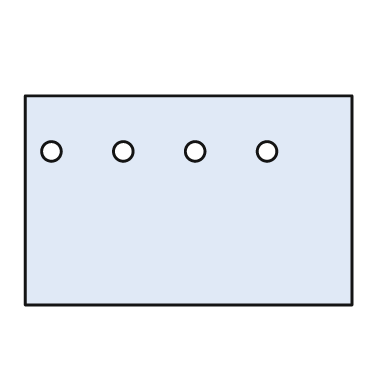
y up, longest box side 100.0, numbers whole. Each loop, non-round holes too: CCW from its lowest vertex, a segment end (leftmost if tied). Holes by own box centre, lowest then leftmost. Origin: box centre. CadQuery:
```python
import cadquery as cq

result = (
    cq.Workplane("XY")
    .moveTo(-50.0, -32.0)
    .lineTo(50.0, -32.0)
    .lineTo(50.0, 32.0)
    .lineTo(-50.0, 32.0)
    .close()
    .moveTo(-42.0, 15.0)
    .circle(3.0)
    .moveTo(-20.0, 15.0)
    .circle(3.0)
    .moveTo(2.0, 15.0)
    .circle(3.0)
    .moveTo(24.0, 15.0)
    .circle(3.0)
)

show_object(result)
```